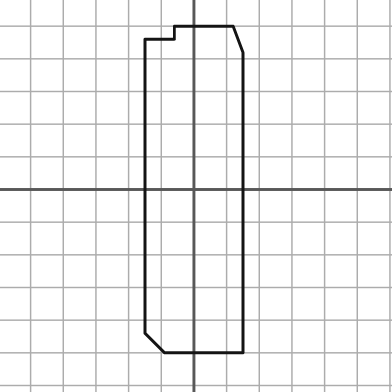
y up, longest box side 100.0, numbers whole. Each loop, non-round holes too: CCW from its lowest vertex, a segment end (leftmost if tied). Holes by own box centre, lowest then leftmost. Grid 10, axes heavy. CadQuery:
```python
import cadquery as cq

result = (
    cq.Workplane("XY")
    .moveTo(-9.0, -50.0)
    .lineTo(15.0, -50.0)
    .lineTo(15.0, 42.0)
    .lineTo(12.0, 50.0)
    .lineTo(-6.0, 50.0)
    .lineTo(-6.0, 46.0)
    .lineTo(-15.0, 46.0)
    .lineTo(-15.0, -44.0)
    .close()
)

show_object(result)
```